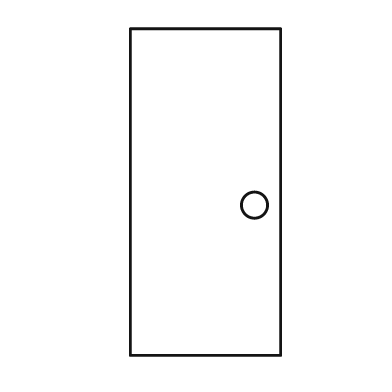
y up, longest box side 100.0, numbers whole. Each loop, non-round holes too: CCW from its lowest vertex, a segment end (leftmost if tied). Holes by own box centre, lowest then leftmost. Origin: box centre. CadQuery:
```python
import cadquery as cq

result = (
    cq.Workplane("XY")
    .moveTo(-23.0, -50.0)
    .lineTo(23.0, -50.0)
    .lineTo(23.0, 50.0)
    .lineTo(-23.0, 50.0)
    .close()
    .moveTo(15.0, -4.0)
    .circle(4.0)
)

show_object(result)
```